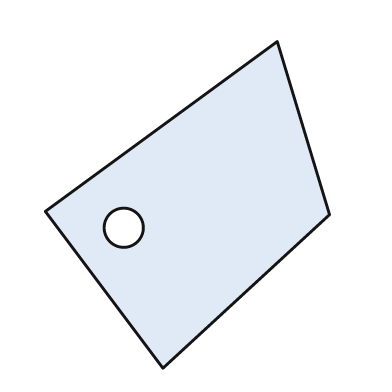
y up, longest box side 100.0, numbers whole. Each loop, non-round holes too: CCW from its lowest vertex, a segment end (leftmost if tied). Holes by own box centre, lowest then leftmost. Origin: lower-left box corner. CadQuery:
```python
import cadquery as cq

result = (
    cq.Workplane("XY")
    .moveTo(36.0, 0.0)
    .lineTo(87.0, 47.0)
    .lineTo(71.0, 100.0)
    .lineTo(0.0, 48.0)
    .close()
    .moveTo(24.0, 43.0)
    .circle(6.0)
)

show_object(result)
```